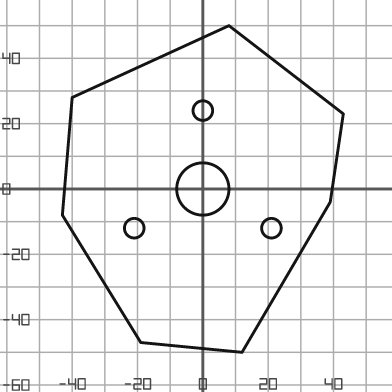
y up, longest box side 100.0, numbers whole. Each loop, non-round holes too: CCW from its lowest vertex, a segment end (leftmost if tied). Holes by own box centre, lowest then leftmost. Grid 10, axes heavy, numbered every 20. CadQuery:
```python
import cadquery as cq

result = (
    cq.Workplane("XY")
    .moveTo(12.0, -50.0)
    .lineTo(39.0, -4.0)
    .lineTo(43.0, 23.0)
    .lineTo(8.0, 50.0)
    .lineTo(-40.0, 28.0)
    .lineTo(-43.0, -8.0)
    .lineTo(-19.0, -47.0)
    .close()
    .moveTo(-21.0, -12.0)
    .circle(3.0)
    .moveTo(21.0, -12.0)
    .circle(3.0)
    .moveTo(0.0, 0.0)
    .circle(8.0)
    .moveTo(0.0, 24.0)
    .circle(3.0)
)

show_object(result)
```